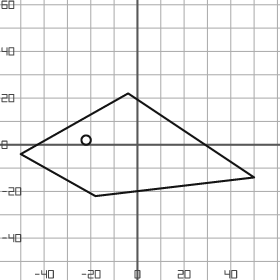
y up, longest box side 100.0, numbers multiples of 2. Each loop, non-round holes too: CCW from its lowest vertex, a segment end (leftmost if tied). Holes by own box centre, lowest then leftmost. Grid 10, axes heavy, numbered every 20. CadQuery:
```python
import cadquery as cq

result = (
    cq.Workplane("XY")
    .moveTo(-18.0, -22.0)
    .lineTo(50.0, -14.0)
    .lineTo(-4.0, 22.0)
    .lineTo(-50.0, -4.0)
    .close()
    .moveTo(-22.0, 2.0)
    .circle(2.0)
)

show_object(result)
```